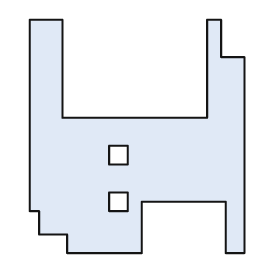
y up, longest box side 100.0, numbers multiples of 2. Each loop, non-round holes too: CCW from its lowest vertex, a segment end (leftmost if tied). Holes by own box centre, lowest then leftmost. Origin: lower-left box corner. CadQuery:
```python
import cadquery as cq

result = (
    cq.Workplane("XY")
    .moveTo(16.0, 0.0)
    .lineTo(48.0, 0.0)
    .lineTo(48.0, 22.0)
    .lineTo(84.0, 22.0)
    .lineTo(84.0, 0.0)
    .lineTo(92.0, 0.0)
    .lineTo(92.0, 84.0)
    .lineTo(82.0, 84.0)
    .lineTo(82.0, 100.0)
    .lineTo(76.0, 100.0)
    .lineTo(76.0, 58.0)
    .lineTo(14.0, 58.0)
    .lineTo(14.0, 100.0)
    .lineTo(0.0, 100.0)
    .lineTo(0.0, 18.0)
    .lineTo(4.0, 18.0)
    .lineTo(4.0, 8.0)
    .lineTo(16.0, 8.0)
    .close()
    .moveTo(34.0, 18.0)
    .lineTo(42.0, 18.0)
    .lineTo(42.0, 26.0)
    .lineTo(34.0, 26.0)
    .close()
    .moveTo(34.0, 38.0)
    .lineTo(42.0, 38.0)
    .lineTo(42.0, 46.0)
    .lineTo(34.0, 46.0)
    .close()
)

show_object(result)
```